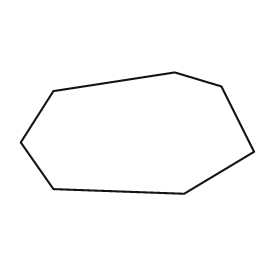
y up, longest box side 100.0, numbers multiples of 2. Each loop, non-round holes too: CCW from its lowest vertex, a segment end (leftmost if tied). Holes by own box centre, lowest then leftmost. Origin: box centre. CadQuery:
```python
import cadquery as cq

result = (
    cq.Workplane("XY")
    .moveTo(20.0, -26.0)
    .lineTo(50.0, -8.0)
    .lineTo(36.0, 20.0)
    .lineTo(16.0, 26.0)
    .lineTo(-36.0, 18.0)
    .lineTo(-50.0, -4.0)
    .lineTo(-36.0, -24.0)
    .close()
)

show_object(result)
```